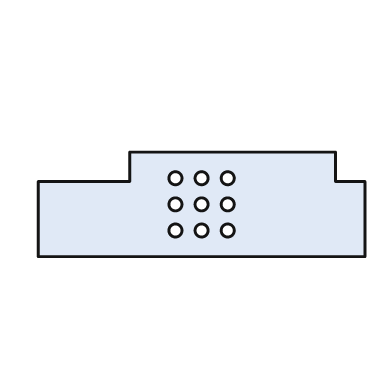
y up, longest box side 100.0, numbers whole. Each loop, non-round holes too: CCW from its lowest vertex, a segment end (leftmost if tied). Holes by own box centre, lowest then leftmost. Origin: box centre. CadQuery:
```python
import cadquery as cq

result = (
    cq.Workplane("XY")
    .moveTo(-50.0, -16.0)
    .lineTo(50.0, -16.0)
    .lineTo(50.0, 7.0)
    .lineTo(41.0, 7.0)
    .lineTo(41.0, 16.0)
    .lineTo(-22.0, 16.0)
    .lineTo(-22.0, 7.0)
    .lineTo(-50.0, 7.0)
    .close()
    .moveTo(-8.0, -8.0)
    .circle(2.0)
    .moveTo(0.0, -8.0)
    .circle(2.0)
    .moveTo(8.0, -8.0)
    .circle(2.0)
    .moveTo(-8.0, 0.0)
    .circle(2.0)
    .moveTo(0.0, 0.0)
    .circle(2.0)
    .moveTo(8.0, 0.0)
    .circle(2.0)
    .moveTo(-8.0, 8.0)
    .circle(2.0)
    .moveTo(0.0, 8.0)
    .circle(2.0)
    .moveTo(8.0, 8.0)
    .circle(2.0)
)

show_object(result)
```